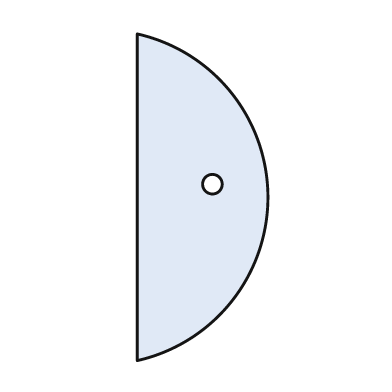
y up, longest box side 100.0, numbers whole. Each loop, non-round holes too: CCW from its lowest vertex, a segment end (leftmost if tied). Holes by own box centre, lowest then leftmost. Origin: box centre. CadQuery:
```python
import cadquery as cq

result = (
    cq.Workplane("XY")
    .moveTo(-20.0, -50.0)
    .threePointArc((20.0, 0.0), (-20.0, 50.0))
    .close()
    .moveTo(3.0, 4.0)
    .circle(3.0)
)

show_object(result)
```